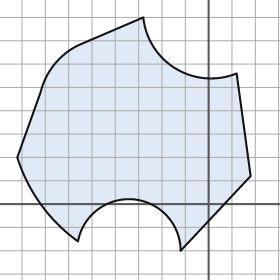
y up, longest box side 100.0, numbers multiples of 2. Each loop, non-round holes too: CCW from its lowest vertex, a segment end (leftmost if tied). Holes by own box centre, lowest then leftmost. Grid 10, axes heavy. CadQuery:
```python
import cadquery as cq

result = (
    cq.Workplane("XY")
    .moveTo(-12.0, -20.0)
    .lineTo(18.0, 12.0)
    .lineTo(12.0, 56.0)
    .threePointArc((-14.0, 58.0), (-28.0, 80.0))
    .lineTo(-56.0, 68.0)
    .threePointArc((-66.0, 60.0), (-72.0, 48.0))
    .lineTo(-82.0, 20.0)
    .threePointArc((-72.0, 0.0), (-56.0, -16.0))
    .threePointArc((-32.0, 2.0), (-12.0, -20.0))
    .close()
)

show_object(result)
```